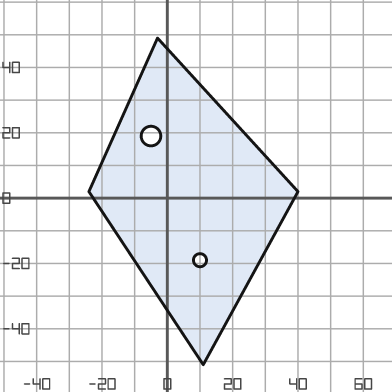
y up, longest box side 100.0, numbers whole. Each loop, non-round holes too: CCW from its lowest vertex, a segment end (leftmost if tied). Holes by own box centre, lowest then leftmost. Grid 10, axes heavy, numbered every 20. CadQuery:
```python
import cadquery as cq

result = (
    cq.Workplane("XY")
    .moveTo(11.0, -51.0)
    .lineTo(40.0, 2.0)
    .lineTo(-3.0, 49.0)
    .lineTo(-24.0, 2.0)
    .close()
    .moveTo(10.0, -19.0)
    .circle(2.0)
    .moveTo(-5.0, 19.0)
    .circle(3.0)
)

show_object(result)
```